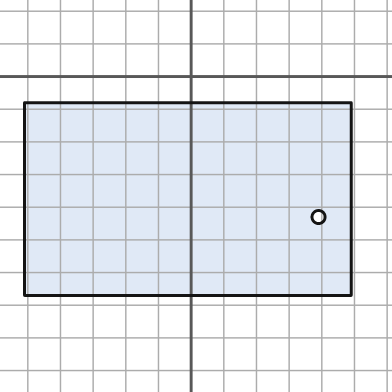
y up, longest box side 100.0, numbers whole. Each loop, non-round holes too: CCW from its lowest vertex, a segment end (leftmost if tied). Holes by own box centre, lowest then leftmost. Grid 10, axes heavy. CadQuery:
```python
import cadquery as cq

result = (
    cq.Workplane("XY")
    .moveTo(-51.0, -67.0)
    .lineTo(49.0, -67.0)
    .lineTo(49.0, -8.0)
    .lineTo(-51.0, -8.0)
    .close()
    .moveTo(39.0, -43.0)
    .circle(2.0)
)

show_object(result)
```